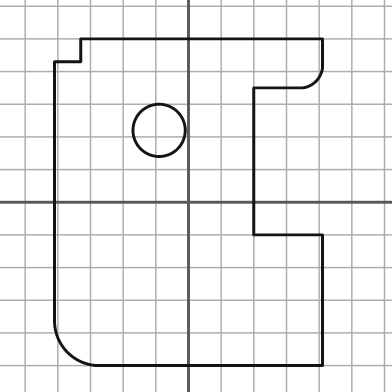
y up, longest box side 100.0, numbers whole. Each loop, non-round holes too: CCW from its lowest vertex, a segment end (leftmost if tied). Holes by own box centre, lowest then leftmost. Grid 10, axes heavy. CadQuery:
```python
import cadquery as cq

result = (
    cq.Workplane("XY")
    .moveTo(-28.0, -50.0)
    .lineTo(41.0, -50.0)
    .lineTo(41.0, -10.0)
    .lineTo(20.0, -10.0)
    .lineTo(20.0, 35.0)
    .lineTo(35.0, 35.0)
    .threePointArc((39.0, 37.0), (41.0, 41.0))
    .lineTo(41.0, 50.0)
    .lineTo(-33.0, 50.0)
    .lineTo(-33.0, 43.0)
    .lineTo(-41.0, 43.0)
    .lineTo(-41.0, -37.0)
    .threePointArc((-37.0, -46.0), (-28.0, -50.0))
    .close()
    .moveTo(-9.0, 22.0)
    .circle(8.0)
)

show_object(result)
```